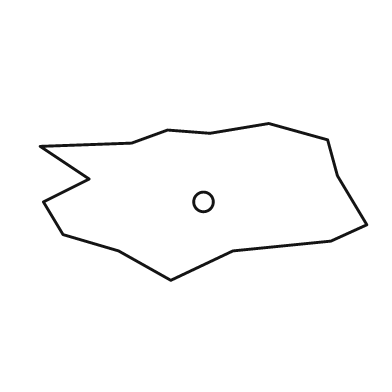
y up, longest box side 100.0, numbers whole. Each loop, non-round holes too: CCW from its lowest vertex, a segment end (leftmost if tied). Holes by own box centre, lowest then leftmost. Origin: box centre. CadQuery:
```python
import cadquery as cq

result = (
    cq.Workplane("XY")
    .moveTo(-10.0, -24.0)
    .lineTo(9.0, -15.0)
    .lineTo(39.0, -12.0)
    .lineTo(50.0, -7.0)
    .lineTo(41.0, 8.0)
    .lineTo(38.0, 19.0)
    .lineTo(20.0, 24.0)
    .lineTo(2.0, 21.0)
    .lineTo(-11.0, 22.0)
    .lineTo(-22.0, 18.0)
    .lineTo(-50.0, 17.0)
    .lineTo(-35.0, 7.0)
    .lineTo(-49.0, 0.0)
    .lineTo(-43.0, -10.0)
    .lineTo(-26.0, -15.0)
    .close()
    .moveTo(0.0, 0.0)
    .circle(3.0)
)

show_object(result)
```